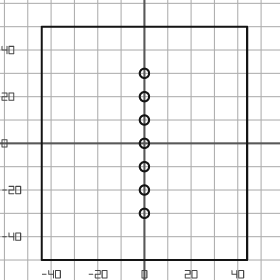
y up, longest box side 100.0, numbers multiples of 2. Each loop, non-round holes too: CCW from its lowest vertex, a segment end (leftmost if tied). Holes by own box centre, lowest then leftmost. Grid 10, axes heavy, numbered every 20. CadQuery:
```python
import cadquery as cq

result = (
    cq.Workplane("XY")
    .moveTo(-44.0, -50.0)
    .lineTo(44.0, -50.0)
    .lineTo(44.0, 50.0)
    .lineTo(-44.0, 50.0)
    .close()
    .moveTo(0.0, -30.0)
    .circle(2.0)
    .moveTo(0.0, -20.0)
    .circle(2.0)
    .moveTo(0.0, -10.0)
    .circle(2.0)
    .moveTo(0.0, 0.0)
    .circle(2.0)
    .moveTo(0.0, 10.0)
    .circle(2.0)
    .moveTo(0.0, 20.0)
    .circle(2.0)
    .moveTo(0.0, 30.0)
    .circle(2.0)
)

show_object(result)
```